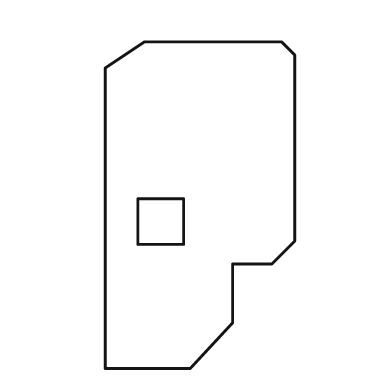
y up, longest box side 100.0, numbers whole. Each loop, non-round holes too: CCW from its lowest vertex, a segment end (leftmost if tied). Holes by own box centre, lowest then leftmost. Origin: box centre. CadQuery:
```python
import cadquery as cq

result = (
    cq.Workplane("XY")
    .moveTo(-29.0, -50.0)
    .lineTo(-3.0, -50.0)
    .lineTo(10.0, -36.0)
    .lineTo(10.0, -18.0)
    .lineTo(22.0, -18.0)
    .lineTo(29.0, -11.0)
    .lineTo(29.0, 46.0)
    .lineTo(25.0, 50.0)
    .lineTo(-17.0, 50.0)
    .lineTo(-29.0, 42.0)
    .close()
    .moveTo(-19.0, -12.0)
    .lineTo(-5.0, -12.0)
    .lineTo(-5.0, 2.0)
    .lineTo(-19.0, 2.0)
    .close()
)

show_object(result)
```